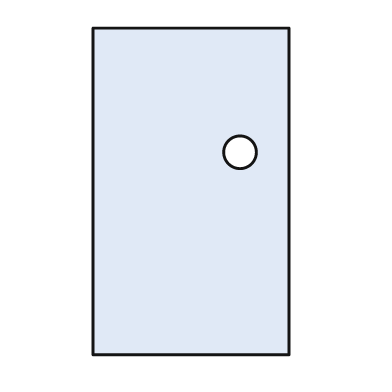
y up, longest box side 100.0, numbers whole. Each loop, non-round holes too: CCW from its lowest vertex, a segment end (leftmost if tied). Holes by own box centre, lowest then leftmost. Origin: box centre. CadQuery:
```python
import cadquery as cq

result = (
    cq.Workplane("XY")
    .moveTo(-30.0, -50.0)
    .lineTo(30.0, -50.0)
    .lineTo(30.0, 50.0)
    .lineTo(-30.0, 50.0)
    .close()
    .moveTo(15.0, 12.0)
    .circle(5.0)
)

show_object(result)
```